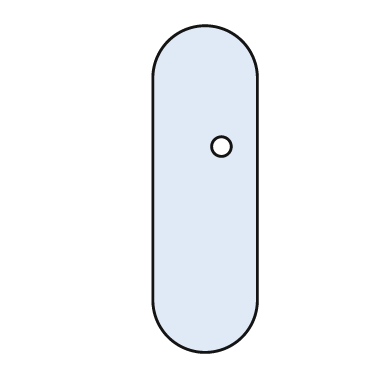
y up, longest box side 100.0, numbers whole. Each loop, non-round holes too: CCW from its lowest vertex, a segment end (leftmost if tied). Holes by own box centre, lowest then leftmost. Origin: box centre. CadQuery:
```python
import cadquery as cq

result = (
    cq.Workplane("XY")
    .moveTo(-16.0, -34.0)
    .threePointArc((0.0, -50.0), (16.0, -34.0))
    .lineTo(16.0, 34.0)
    .threePointArc((0.0, 50.0), (-16.0, 34.0))
    .close()
    .moveTo(5.0, 13.0)
    .circle(3.0)
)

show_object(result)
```